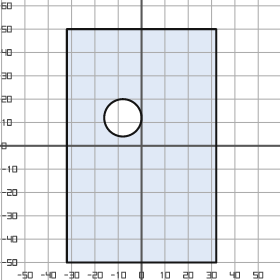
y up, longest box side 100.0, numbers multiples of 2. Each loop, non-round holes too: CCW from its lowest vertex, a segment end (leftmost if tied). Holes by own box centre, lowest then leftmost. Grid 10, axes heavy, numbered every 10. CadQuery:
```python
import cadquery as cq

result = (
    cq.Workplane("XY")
    .moveTo(-32.0, -50.0)
    .lineTo(32.0, -50.0)
    .lineTo(32.0, 50.0)
    .lineTo(-32.0, 50.0)
    .close()
    .moveTo(-8.0, 12.0)
    .circle(8.0)
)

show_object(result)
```